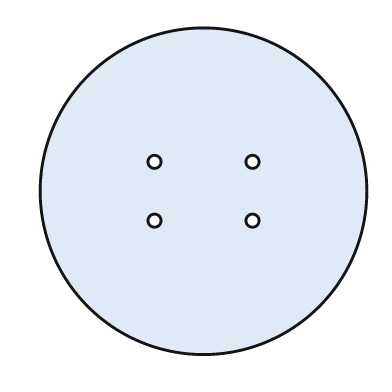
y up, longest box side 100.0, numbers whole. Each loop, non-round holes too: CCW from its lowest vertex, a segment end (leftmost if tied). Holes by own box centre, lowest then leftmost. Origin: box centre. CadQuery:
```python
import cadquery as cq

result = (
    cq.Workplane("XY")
    .moveTo(0.0, 0.0)
    .circle(50.0)
    .moveTo(-15.0, -9.0)
    .circle(2.0)
    .moveTo(15.0, -9.0)
    .circle(2.0)
    .moveTo(-15.0, 9.0)
    .circle(2.0)
    .moveTo(15.0, 9.0)
    .circle(2.0)
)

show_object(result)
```